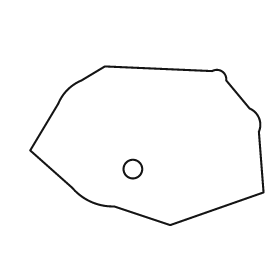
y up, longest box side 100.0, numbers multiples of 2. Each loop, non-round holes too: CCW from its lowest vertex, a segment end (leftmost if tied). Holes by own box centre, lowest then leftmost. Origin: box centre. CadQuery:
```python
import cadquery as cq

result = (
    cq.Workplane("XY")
    .moveTo(10.0, -34.0)
    .lineTo(50.0, -20.0)
    .lineTo(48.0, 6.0)
    .threePointArc((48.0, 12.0), (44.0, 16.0))
    .lineTo(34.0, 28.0)
    .threePointArc((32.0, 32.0), (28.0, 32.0))
    .lineTo(-18.0, 34.0)
    .lineTo(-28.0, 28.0)
    .threePointArc((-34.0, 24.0), (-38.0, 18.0))
    .lineTo(-50.0, -2.0)
    .lineTo(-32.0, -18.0)
    .threePointArc((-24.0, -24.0), (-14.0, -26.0))
    .close()
    .moveTo(-6.0, -10.0)
    .circle(4.0)
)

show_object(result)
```